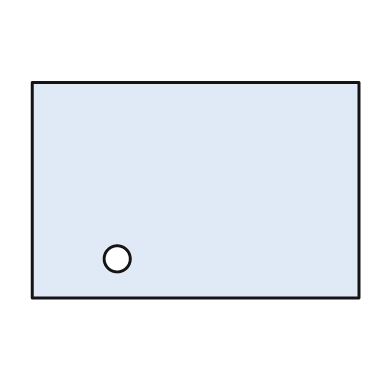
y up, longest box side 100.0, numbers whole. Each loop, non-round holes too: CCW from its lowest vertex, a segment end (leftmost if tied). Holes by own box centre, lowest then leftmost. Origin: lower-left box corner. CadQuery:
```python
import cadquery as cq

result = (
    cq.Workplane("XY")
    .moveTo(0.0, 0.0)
    .lineTo(100.0, 0.0)
    .lineTo(100.0, 66.0)
    .lineTo(0.0, 66.0)
    .close()
    .moveTo(26.0, 12.0)
    .circle(4.0)
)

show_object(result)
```